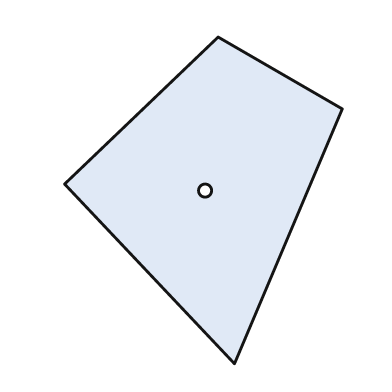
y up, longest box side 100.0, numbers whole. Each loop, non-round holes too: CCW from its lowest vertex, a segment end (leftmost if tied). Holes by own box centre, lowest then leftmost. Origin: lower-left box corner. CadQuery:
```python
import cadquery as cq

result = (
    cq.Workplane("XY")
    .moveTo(52.0, 0.0)
    .lineTo(85.0, 78.0)
    .lineTo(47.0, 100.0)
    .lineTo(0.0, 55.0)
    .close()
    .moveTo(43.0, 53.0)
    .circle(2.0)
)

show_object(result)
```